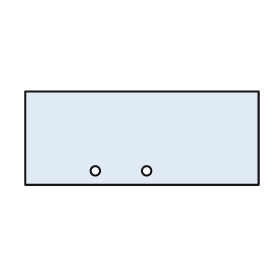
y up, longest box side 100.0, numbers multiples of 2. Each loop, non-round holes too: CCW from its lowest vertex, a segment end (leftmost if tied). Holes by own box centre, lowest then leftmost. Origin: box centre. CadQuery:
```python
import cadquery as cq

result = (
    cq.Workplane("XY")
    .moveTo(-50.0, -20.0)
    .lineTo(50.0, -20.0)
    .lineTo(50.0, 20.0)
    .lineTo(-50.0, 20.0)
    .close()
    .moveTo(-20.0, -14.0)
    .circle(2.0)
    .moveTo(2.0, -14.0)
    .circle(2.0)
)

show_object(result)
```